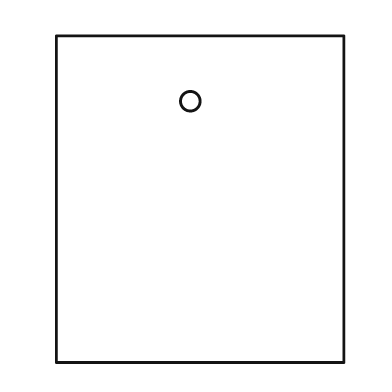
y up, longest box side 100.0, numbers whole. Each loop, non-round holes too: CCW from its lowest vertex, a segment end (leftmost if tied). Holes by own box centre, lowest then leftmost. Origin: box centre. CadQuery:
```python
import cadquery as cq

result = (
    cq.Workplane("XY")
    .moveTo(-44.0, -50.0)
    .lineTo(44.0, -50.0)
    .lineTo(44.0, 50.0)
    .lineTo(-44.0, 50.0)
    .close()
    .moveTo(-3.0, 30.0)
    .circle(3.0)
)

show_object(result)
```